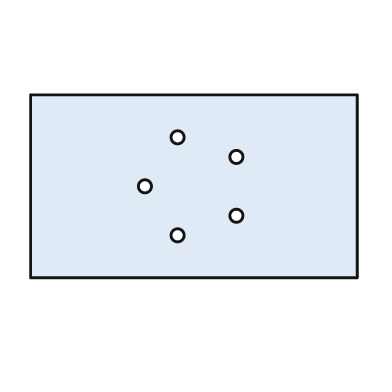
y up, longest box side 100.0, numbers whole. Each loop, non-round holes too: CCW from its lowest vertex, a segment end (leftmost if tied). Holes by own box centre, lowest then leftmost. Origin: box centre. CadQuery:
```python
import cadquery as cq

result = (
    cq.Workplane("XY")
    .moveTo(-50.0, -28.0)
    .lineTo(50.0, -28.0)
    .lineTo(50.0, 28.0)
    .lineTo(-50.0, 28.0)
    .close()
    .moveTo(-5.0, -15.0)
    .circle(2.0)
    .moveTo(13.0, -9.0)
    .circle(2.0)
    .moveTo(-15.0, 0.0)
    .circle(2.0)
    .moveTo(13.0, 9.0)
    .circle(2.0)
    .moveTo(-5.0, 15.0)
    .circle(2.0)
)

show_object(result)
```